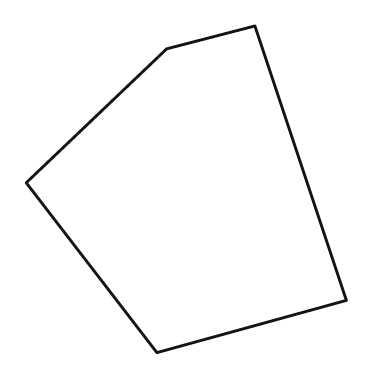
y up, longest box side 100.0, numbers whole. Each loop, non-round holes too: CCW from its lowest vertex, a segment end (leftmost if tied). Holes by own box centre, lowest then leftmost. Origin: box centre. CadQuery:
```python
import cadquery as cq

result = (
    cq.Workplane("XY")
    .moveTo(-9.0, -50.0)
    .lineTo(49.0, -34.0)
    .lineTo(21.0, 50.0)
    .lineTo(-6.0, 43.0)
    .lineTo(-49.0, 2.0)
    .close()
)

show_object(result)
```